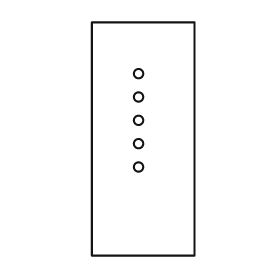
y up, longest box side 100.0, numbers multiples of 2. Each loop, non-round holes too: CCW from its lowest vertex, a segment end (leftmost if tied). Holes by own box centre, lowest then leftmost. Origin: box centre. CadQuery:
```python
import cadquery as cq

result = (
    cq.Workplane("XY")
    .moveTo(-22.0, -50.0)
    .lineTo(22.0, -50.0)
    .lineTo(22.0, 50.0)
    .lineTo(-22.0, 50.0)
    .close()
    .moveTo(-2.0, -12.0)
    .circle(2.0)
    .moveTo(-2.0, -2.0)
    .circle(2.0)
    .moveTo(-2.0, 8.0)
    .circle(2.0)
    .moveTo(-2.0, 18.0)
    .circle(2.0)
    .moveTo(-2.0, 28.0)
    .circle(2.0)
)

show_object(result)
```